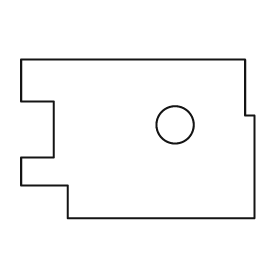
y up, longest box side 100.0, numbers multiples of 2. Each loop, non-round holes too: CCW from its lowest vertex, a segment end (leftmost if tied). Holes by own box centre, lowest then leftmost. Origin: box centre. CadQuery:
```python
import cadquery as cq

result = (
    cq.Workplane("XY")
    .moveTo(-30.0, -34.0)
    .lineTo(50.0, -34.0)
    .lineTo(50.0, 10.0)
    .lineTo(46.0, 10.0)
    .lineTo(46.0, 34.0)
    .lineTo(-50.0, 34.0)
    .lineTo(-50.0, 16.0)
    .lineTo(-36.0, 16.0)
    .lineTo(-36.0, -8.0)
    .lineTo(-50.0, -8.0)
    .lineTo(-50.0, -20.0)
    .lineTo(-30.0, -20.0)
    .close()
    .moveTo(16.0, 6.0)
    .circle(8.0)
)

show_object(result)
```